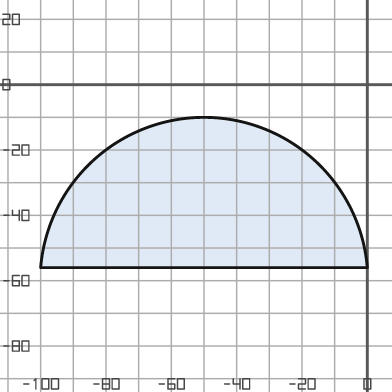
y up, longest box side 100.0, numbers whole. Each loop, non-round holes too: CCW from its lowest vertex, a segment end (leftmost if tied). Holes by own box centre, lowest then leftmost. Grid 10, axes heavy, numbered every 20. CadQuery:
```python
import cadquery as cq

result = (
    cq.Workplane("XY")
    .moveTo(-100.0, -56.0)
    .lineTo(0.0, -56.0)
    .threePointArc((-50.0, -10.0), (-100.0, -56.0))
    .close()
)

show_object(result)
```